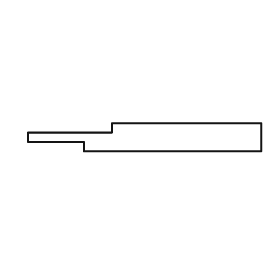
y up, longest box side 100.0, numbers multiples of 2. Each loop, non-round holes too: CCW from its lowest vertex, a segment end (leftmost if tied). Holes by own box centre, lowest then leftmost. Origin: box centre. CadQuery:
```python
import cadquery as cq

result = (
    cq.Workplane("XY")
    .moveTo(-26.0, -6.0)
    .lineTo(50.0, -6.0)
    .lineTo(50.0, 6.0)
    .lineTo(-14.0, 6.0)
    .lineTo(-14.0, 2.0)
    .lineTo(-50.0, 2.0)
    .lineTo(-50.0, -2.0)
    .lineTo(-26.0, -2.0)
    .close()
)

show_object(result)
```